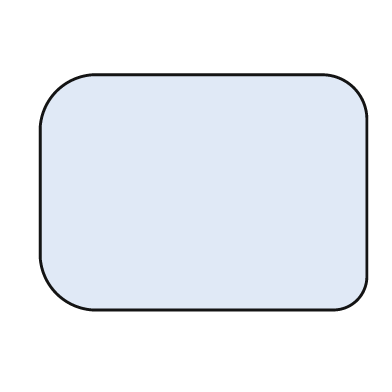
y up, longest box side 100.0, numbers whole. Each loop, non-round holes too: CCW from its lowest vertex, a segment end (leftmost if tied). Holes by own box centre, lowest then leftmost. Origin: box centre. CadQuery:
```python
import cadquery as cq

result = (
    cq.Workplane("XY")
    .moveTo(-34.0, -36.0)
    .lineTo(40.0, -36.0)
    .threePointArc((47.0, -33.0), (50.0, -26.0))
    .lineTo(50.0, 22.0)
    .threePointArc((46.0, 32.0), (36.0, 36.0))
    .lineTo(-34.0, 36.0)
    .threePointArc((-45.0, 31.0), (-50.0, 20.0))
    .lineTo(-50.0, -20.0)
    .threePointArc((-45.0, -31.0), (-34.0, -36.0))
    .close()
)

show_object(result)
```